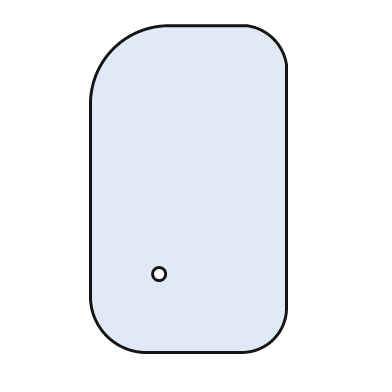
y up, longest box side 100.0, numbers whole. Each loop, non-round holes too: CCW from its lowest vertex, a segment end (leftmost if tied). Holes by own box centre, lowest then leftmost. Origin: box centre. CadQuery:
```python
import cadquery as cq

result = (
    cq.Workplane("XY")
    .moveTo(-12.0, -50.0)
    .lineTo(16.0, -50.0)
    .threePointArc((26.0, -46.0), (30.0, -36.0))
    .lineTo(30.0, 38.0)
    .threePointArc((26.0, 46.0), (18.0, 50.0))
    .lineTo(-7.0, 50.0)
    .threePointArc((-23.0, 43.0), (-30.0, 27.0))
    .lineTo(-30.0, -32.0)
    .threePointArc((-25.0, -45.0), (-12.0, -50.0))
    .close()
    .moveTo(-9.0, -26.0)
    .circle(2.0)
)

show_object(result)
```